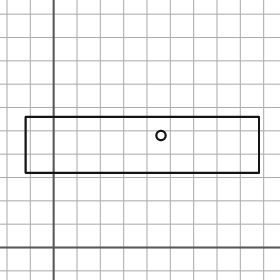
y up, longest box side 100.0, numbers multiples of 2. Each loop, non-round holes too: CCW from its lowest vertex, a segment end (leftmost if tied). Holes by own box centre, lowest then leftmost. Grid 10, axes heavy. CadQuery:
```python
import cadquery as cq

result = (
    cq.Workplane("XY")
    .moveTo(-12.0, 32.0)
    .lineTo(88.0, 32.0)
    .lineTo(88.0, 56.0)
    .lineTo(-12.0, 56.0)
    .close()
    .moveTo(46.0, 48.0)
    .circle(2.0)
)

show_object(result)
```